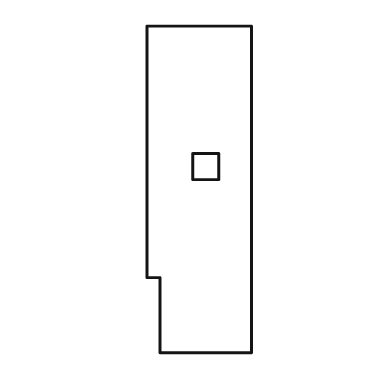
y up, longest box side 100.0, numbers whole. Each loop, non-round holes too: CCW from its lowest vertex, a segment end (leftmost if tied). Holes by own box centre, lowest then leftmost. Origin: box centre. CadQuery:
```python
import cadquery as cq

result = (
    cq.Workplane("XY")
    .moveTo(-12.0, -50.0)
    .lineTo(16.0, -50.0)
    .lineTo(16.0, 50.0)
    .lineTo(-16.0, 50.0)
    .lineTo(-16.0, -27.0)
    .lineTo(-12.0, -27.0)
    .close()
    .moveTo(-2.0, 3.0)
    .lineTo(6.0, 3.0)
    .lineTo(6.0, 11.0)
    .lineTo(-2.0, 11.0)
    .close()
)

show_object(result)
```